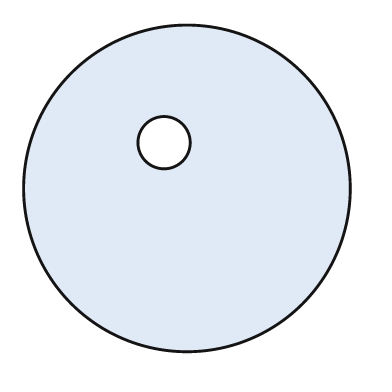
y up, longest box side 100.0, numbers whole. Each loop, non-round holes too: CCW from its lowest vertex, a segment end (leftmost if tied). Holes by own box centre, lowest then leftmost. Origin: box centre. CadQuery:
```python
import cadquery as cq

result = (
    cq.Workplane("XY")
    .moveTo(0.0, 0.0)
    .circle(50.0)
    .moveTo(-7.0, 14.0)
    .circle(8.0)
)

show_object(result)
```